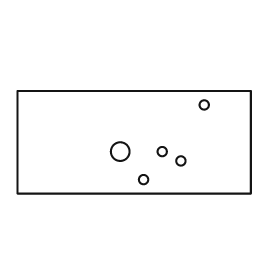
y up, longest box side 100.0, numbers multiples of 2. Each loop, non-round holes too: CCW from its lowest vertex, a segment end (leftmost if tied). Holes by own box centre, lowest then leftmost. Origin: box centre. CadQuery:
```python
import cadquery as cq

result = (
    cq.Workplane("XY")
    .moveTo(-50.0, -22.0)
    .lineTo(50.0, -22.0)
    .lineTo(50.0, 22.0)
    .lineTo(-50.0, 22.0)
    .close()
    .moveTo(4.0, -16.0)
    .circle(2.0)
    .moveTo(20.0, -8.0)
    .circle(2.0)
    .moveTo(-6.0, -4.0)
    .circle(4.0)
    .moveTo(12.0, -4.0)
    .circle(2.0)
    .moveTo(30.0, 16.0)
    .circle(2.0)
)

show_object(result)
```